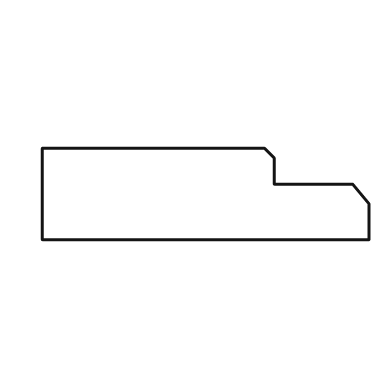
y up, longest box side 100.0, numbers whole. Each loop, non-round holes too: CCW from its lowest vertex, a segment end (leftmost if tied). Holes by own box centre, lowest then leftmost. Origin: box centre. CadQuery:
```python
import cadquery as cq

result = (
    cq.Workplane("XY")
    .moveTo(-50.0, -14.0)
    .lineTo(50.0, -14.0)
    .lineTo(50.0, -3.0)
    .lineTo(45.0, 3.0)
    .lineTo(21.0, 3.0)
    .lineTo(21.0, 11.0)
    .lineTo(18.0, 14.0)
    .lineTo(-50.0, 14.0)
    .close()
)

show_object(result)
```